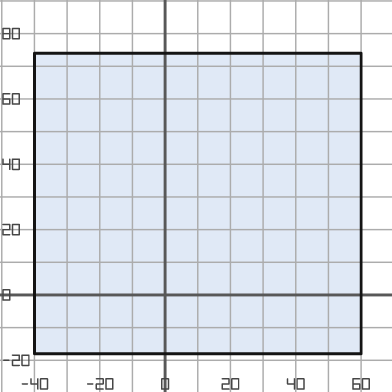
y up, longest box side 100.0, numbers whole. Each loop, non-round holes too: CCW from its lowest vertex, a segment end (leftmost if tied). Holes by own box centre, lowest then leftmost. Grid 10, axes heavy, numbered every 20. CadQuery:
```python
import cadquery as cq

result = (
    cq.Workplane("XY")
    .moveTo(-40.0, -18.0)
    .lineTo(60.0, -18.0)
    .lineTo(60.0, 74.0)
    .lineTo(-40.0, 74.0)
    .close()
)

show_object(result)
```